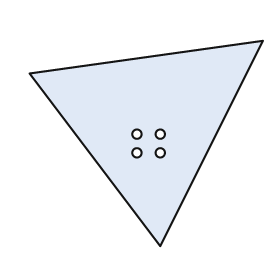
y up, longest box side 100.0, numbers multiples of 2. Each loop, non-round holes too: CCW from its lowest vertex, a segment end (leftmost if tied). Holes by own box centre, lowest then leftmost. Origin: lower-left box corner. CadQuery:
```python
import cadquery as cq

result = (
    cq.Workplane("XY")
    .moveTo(56.0, 0.0)
    .lineTo(100.0, 88.0)
    .lineTo(0.0, 74.0)
    .close()
    .moveTo(46.0, 40.0)
    .circle(2.0)
    .moveTo(56.0, 40.0)
    .circle(2.0)
    .moveTo(46.0, 48.0)
    .circle(2.0)
    .moveTo(56.0, 48.0)
    .circle(2.0)
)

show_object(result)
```